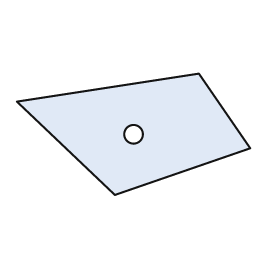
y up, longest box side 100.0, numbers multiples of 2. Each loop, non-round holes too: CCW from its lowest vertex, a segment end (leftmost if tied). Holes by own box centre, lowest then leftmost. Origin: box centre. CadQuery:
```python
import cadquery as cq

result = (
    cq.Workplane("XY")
    .moveTo(-8.0, -26.0)
    .lineTo(50.0, -6.0)
    .lineTo(28.0, 26.0)
    .lineTo(-50.0, 14.0)
    .close()
    .moveTo(0.0, 0.0)
    .circle(4.0)
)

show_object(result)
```